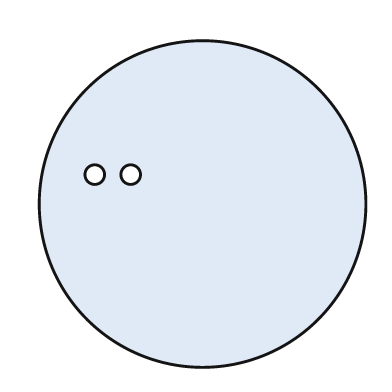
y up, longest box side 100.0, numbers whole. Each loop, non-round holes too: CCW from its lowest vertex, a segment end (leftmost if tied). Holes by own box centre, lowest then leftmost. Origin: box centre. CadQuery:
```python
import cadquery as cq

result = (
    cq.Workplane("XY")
    .moveTo(0.0, 0.0)
    .circle(50.0)
    .moveTo(-33.0, 9.0)
    .circle(3.0)
    .moveTo(-22.0, 9.0)
    .circle(3.0)
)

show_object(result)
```